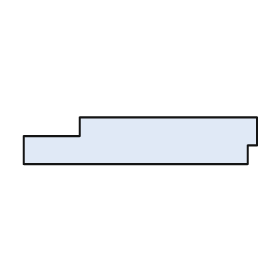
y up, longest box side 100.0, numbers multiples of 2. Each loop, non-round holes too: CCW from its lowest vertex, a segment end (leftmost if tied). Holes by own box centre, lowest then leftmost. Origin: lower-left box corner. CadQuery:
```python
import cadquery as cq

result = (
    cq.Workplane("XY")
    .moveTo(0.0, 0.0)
    .lineTo(96.0, 0.0)
    .lineTo(96.0, 8.0)
    .lineTo(100.0, 8.0)
    .lineTo(100.0, 20.0)
    .lineTo(24.0, 20.0)
    .lineTo(24.0, 12.0)
    .lineTo(0.0, 12.0)
    .close()
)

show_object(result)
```